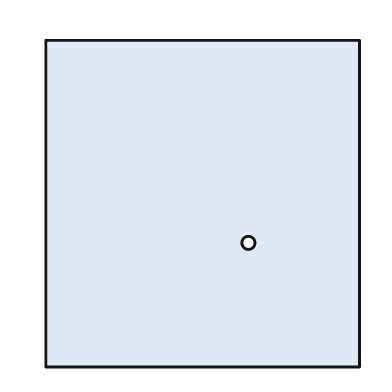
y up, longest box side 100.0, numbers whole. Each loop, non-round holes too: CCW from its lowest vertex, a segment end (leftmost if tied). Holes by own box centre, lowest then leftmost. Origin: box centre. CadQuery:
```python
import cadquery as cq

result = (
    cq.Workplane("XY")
    .moveTo(-48.0, -50.0)
    .lineTo(48.0, -50.0)
    .lineTo(48.0, 50.0)
    .lineTo(-48.0, 50.0)
    .close()
    .moveTo(14.0, -12.0)
    .circle(2.0)
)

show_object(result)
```